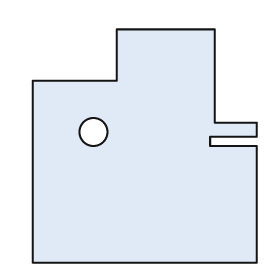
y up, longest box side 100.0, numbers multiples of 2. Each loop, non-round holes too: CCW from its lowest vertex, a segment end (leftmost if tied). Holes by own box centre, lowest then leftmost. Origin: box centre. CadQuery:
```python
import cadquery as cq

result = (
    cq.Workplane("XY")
    .moveTo(-48.0, -50.0)
    .lineTo(48.0, -50.0)
    .lineTo(48.0, 0.0)
    .lineTo(28.0, 0.0)
    .lineTo(28.0, 4.0)
    .lineTo(48.0, 4.0)
    .lineTo(48.0, 10.0)
    .lineTo(30.0, 10.0)
    .lineTo(30.0, 50.0)
    .lineTo(-12.0, 50.0)
    .lineTo(-12.0, 28.0)
    .lineTo(-48.0, 28.0)
    .close()
    .moveTo(-22.0, 6.0)
    .circle(6.0)
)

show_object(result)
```